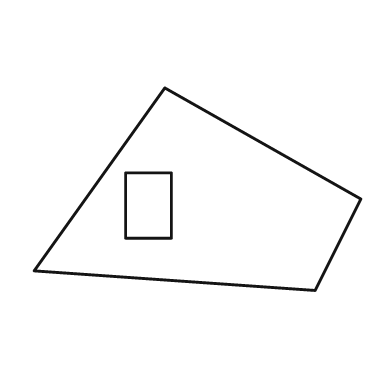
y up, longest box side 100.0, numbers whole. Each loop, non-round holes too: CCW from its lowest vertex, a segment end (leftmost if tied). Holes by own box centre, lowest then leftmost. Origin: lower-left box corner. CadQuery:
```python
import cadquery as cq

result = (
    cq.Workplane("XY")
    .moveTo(86.0, 0.0)
    .lineTo(100.0, 28.0)
    .lineTo(40.0, 62.0)
    .lineTo(0.0, 6.0)
    .close()
    .moveTo(28.0, 16.0)
    .lineTo(42.0, 16.0)
    .lineTo(42.0, 36.0)
    .lineTo(28.0, 36.0)
    .close()
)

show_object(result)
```